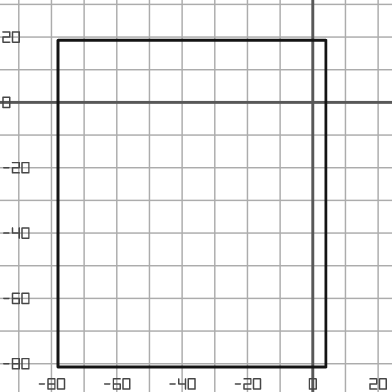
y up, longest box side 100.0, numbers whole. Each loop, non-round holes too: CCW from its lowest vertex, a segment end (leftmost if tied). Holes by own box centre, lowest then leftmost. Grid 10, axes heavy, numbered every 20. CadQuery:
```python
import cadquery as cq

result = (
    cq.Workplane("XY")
    .moveTo(-78.0, -81.0)
    .lineTo(4.0, -81.0)
    .lineTo(4.0, 19.0)
    .lineTo(-78.0, 19.0)
    .close()
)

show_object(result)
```